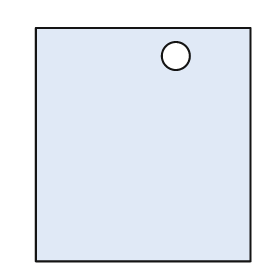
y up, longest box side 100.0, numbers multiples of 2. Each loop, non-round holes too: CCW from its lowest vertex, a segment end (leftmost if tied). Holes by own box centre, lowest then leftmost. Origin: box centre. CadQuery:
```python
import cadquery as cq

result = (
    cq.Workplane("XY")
    .moveTo(-46.0, -50.0)
    .lineTo(46.0, -50.0)
    .lineTo(46.0, 50.0)
    .lineTo(-46.0, 50.0)
    .close()
    .moveTo(14.0, 38.0)
    .circle(6.0)
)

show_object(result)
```